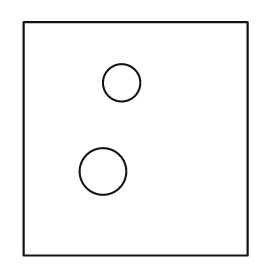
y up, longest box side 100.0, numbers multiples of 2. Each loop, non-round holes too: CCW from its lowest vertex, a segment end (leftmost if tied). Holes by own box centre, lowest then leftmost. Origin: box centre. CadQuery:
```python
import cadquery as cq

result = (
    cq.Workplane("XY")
    .moveTo(-48.0, -50.0)
    .lineTo(48.0, -50.0)
    .lineTo(48.0, 50.0)
    .lineTo(-48.0, 50.0)
    .close()
    .moveTo(-14.0, -14.0)
    .circle(10.0)
    .moveTo(-6.0, 24.0)
    .circle(8.0)
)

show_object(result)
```